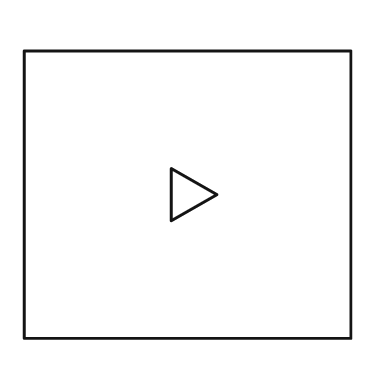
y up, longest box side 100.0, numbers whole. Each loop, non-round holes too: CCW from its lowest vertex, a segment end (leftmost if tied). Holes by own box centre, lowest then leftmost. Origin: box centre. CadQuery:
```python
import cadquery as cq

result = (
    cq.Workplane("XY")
    .moveTo(-50.0, -44.0)
    .lineTo(50.0, -44.0)
    .lineTo(50.0, 44.0)
    .lineTo(-50.0, 44.0)
    .close()
    .moveTo(-5.0, -8.0)
    .lineTo(9.0, 0.0)
    .lineTo(-5.0, 8.0)
    .close()
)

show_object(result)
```